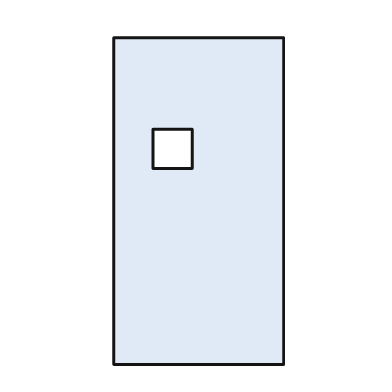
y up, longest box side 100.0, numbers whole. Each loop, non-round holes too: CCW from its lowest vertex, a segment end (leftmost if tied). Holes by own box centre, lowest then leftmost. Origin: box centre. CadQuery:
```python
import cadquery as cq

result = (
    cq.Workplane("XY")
    .moveTo(-26.0, -50.0)
    .lineTo(26.0, -50.0)
    .lineTo(26.0, 50.0)
    .lineTo(-26.0, 50.0)
    .close()
    .moveTo(-14.0, 10.0)
    .lineTo(-2.0, 10.0)
    .lineTo(-2.0, 22.0)
    .lineTo(-14.0, 22.0)
    .close()
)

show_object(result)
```